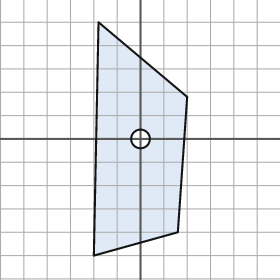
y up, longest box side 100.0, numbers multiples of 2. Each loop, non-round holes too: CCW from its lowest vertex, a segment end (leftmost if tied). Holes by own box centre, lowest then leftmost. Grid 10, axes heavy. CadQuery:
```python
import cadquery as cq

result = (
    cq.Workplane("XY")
    .moveTo(-20.0, -50.0)
    .lineTo(16.0, -40.0)
    .lineTo(20.0, 18.0)
    .lineTo(-18.0, 50.0)
    .close()
    .moveTo(0.0, 0.0)
    .circle(4.0)
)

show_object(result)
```